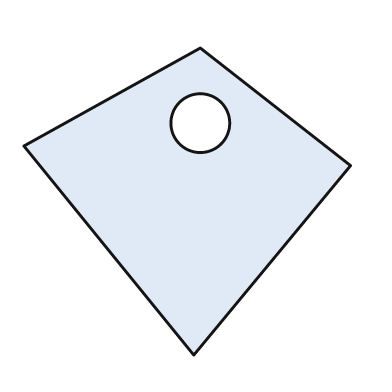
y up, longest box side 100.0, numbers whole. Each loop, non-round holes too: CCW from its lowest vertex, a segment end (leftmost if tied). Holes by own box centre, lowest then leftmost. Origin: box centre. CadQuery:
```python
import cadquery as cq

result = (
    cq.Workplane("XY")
    .moveTo(2.0, -47.0)
    .lineTo(50.0, 11.0)
    .lineTo(4.0, 47.0)
    .lineTo(-50.0, 17.0)
    .close()
    .moveTo(4.0, 24.0)
    .circle(9.0)
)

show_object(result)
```